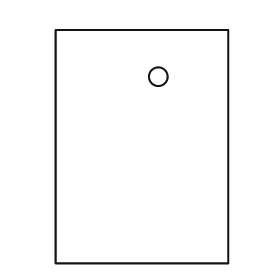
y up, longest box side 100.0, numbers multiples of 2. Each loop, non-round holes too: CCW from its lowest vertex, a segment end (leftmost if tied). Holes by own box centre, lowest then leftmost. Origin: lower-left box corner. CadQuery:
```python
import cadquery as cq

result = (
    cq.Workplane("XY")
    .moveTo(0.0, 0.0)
    .lineTo(74.0, 0.0)
    .lineTo(74.0, 100.0)
    .lineTo(0.0, 100.0)
    .close()
    .moveTo(44.0, 80.0)
    .circle(4.0)
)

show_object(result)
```